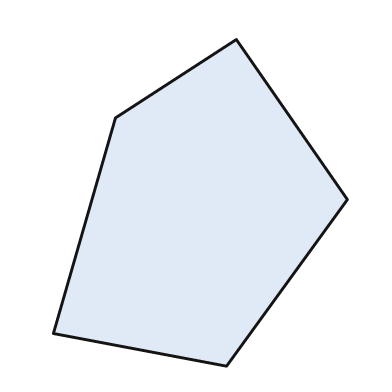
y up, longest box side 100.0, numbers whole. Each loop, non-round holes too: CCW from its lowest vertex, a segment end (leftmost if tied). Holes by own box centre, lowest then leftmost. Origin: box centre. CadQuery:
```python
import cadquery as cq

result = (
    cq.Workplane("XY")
    .moveTo(8.0, -50.0)
    .lineTo(45.0, 1.0)
    .lineTo(11.0, 50.0)
    .lineTo(-26.0, 26.0)
    .lineTo(-45.0, -40.0)
    .close()
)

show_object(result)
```